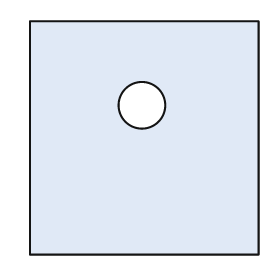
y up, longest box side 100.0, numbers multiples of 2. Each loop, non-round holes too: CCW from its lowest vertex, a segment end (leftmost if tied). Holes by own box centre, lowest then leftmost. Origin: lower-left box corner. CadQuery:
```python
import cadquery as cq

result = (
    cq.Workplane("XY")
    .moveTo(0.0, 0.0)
    .lineTo(98.0, 0.0)
    .lineTo(98.0, 100.0)
    .lineTo(0.0, 100.0)
    .close()
    .moveTo(48.0, 64.0)
    .circle(10.0)
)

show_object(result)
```